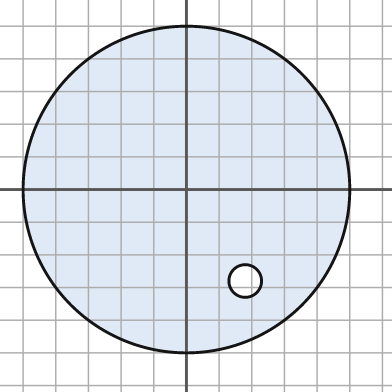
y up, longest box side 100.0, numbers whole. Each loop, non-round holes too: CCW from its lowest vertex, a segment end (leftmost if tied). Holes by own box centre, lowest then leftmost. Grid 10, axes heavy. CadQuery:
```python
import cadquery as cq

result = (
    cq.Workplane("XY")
    .moveTo(0.0, 0.0)
    .circle(50.0)
    .moveTo(18.0, -28.0)
    .circle(5.0)
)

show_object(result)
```